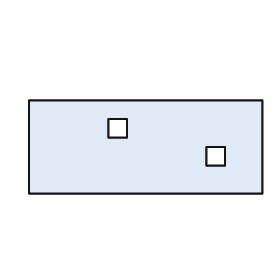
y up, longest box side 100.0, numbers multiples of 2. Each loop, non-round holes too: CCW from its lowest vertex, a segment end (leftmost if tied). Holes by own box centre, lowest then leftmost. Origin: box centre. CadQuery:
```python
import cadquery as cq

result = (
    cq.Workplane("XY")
    .moveTo(-50.0, -20.0)
    .lineTo(50.0, -20.0)
    .lineTo(50.0, 20.0)
    .lineTo(-50.0, 20.0)
    .close()
    .moveTo(26.0, -8.0)
    .lineTo(34.0, -8.0)
    .lineTo(34.0, 0.0)
    .lineTo(26.0, 0.0)
    .close()
    .moveTo(-16.0, 4.0)
    .lineTo(-8.0, 4.0)
    .lineTo(-8.0, 12.0)
    .lineTo(-16.0, 12.0)
    .close()
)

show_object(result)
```